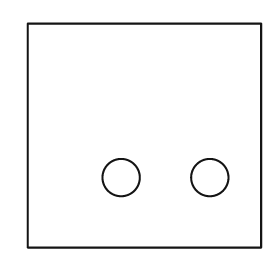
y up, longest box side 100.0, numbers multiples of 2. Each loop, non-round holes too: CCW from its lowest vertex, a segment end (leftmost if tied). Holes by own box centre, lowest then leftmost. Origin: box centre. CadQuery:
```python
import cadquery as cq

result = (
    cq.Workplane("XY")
    .moveTo(-50.0, -48.0)
    .lineTo(50.0, -48.0)
    .lineTo(50.0, 48.0)
    .lineTo(-50.0, 48.0)
    .close()
    .moveTo(-10.0, -18.0)
    .circle(8.0)
    .moveTo(28.0, -18.0)
    .circle(8.0)
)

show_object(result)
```